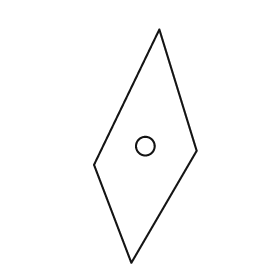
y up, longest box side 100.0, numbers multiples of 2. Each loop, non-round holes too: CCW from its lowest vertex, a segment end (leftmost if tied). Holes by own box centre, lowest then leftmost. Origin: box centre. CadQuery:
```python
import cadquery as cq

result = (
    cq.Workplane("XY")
    .moveTo(-6.0, -50.0)
    .lineTo(22.0, -2.0)
    .lineTo(6.0, 50.0)
    .lineTo(-22.0, -8.0)
    .close()
    .moveTo(0.0, 0.0)
    .circle(4.0)
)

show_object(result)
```